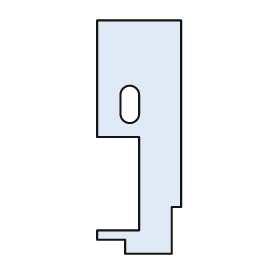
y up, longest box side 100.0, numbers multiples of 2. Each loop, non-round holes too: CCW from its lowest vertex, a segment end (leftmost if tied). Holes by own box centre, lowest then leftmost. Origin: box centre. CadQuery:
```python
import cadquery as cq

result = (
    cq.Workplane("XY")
    .moveTo(-6.0, -50.0)
    .lineTo(14.0, -50.0)
    .lineTo(14.0, -30.0)
    .lineTo(18.0, -30.0)
    .lineTo(18.0, 50.0)
    .lineTo(-18.0, 50.0)
    .lineTo(-18.0, 0.0)
    .lineTo(0.0, 0.0)
    .lineTo(0.0, -40.0)
    .lineTo(-18.0, -40.0)
    .lineTo(-18.0, -44.0)
    .lineTo(-6.0, -44.0)
    .close()
    .moveTo(-8.0, 10.0)
    .threePointArc((-4.0, 6.0), (0.0, 10.0))
    .lineTo(0.0, 18.0)
    .threePointArc((-4.0, 22.0), (-8.0, 18.0))
    .close()
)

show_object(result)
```